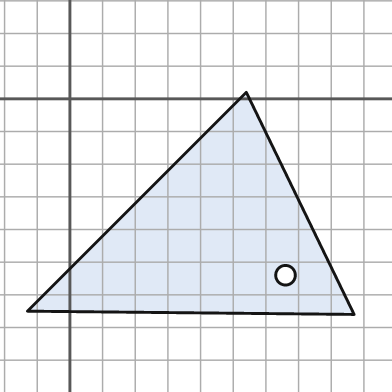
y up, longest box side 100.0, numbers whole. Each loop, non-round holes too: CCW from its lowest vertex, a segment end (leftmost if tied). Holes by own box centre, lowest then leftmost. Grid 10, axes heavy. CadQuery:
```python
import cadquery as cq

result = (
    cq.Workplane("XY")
    .moveTo(87.0, -66.0)
    .lineTo(54.0, 2.0)
    .lineTo(-13.0, -65.0)
    .close()
    .moveTo(66.0, -54.0)
    .circle(3.0)
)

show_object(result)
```